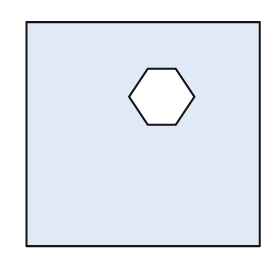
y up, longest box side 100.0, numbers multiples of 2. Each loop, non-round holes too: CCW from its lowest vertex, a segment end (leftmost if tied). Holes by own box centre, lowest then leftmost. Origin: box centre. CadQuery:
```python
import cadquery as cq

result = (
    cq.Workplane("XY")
    .moveTo(-50.0, -48.0)
    .lineTo(50.0, -48.0)
    .lineTo(50.0, 48.0)
    .lineTo(-50.0, 48.0)
    .close()
    .moveTo(2.0, 4.0)
    .lineTo(14.0, 4.0)
    .lineTo(22.0, 16.0)
    .lineTo(14.0, 28.0)
    .lineTo(2.0, 28.0)
    .lineTo(-6.0, 16.0)
    .close()
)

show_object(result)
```